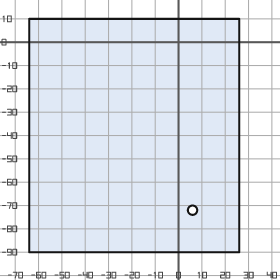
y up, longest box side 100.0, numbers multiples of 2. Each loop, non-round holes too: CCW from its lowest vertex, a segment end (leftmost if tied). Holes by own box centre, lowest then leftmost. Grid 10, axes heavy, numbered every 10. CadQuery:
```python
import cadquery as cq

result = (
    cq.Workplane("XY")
    .moveTo(-64.0, -90.0)
    .lineTo(26.0, -90.0)
    .lineTo(26.0, 10.0)
    .lineTo(-64.0, 10.0)
    .close()
    .moveTo(6.0, -72.0)
    .circle(2.0)
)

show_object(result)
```